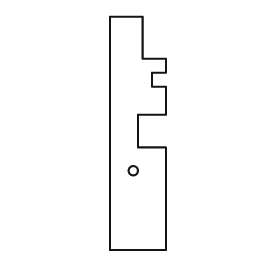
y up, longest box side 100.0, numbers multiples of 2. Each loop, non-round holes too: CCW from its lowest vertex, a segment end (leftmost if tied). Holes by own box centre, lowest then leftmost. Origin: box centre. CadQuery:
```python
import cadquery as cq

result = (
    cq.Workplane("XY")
    .moveTo(-12.0, -50.0)
    .lineTo(12.0, -50.0)
    .lineTo(12.0, -6.0)
    .lineTo(0.0, -6.0)
    .lineTo(0.0, 8.0)
    .lineTo(12.0, 8.0)
    .lineTo(12.0, 20.0)
    .lineTo(6.0, 20.0)
    .lineTo(6.0, 26.0)
    .lineTo(12.0, 26.0)
    .lineTo(12.0, 32.0)
    .lineTo(2.0, 32.0)
    .lineTo(2.0, 50.0)
    .lineTo(-12.0, 50.0)
    .close()
    .moveTo(-2.0, -16.0)
    .circle(2.0)
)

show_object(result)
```